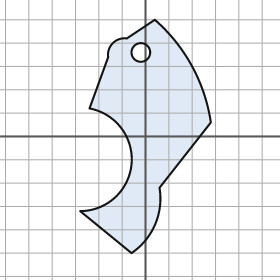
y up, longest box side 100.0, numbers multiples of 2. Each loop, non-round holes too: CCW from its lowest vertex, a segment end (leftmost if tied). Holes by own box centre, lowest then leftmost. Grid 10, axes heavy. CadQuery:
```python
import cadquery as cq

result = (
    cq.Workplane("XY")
    .moveTo(-6.0, -50.0)
    .threePointArc((4.0, -38.0), (6.0, -22.0))
    .lineTo(28.0, 6.0)
    .threePointArc((20.0, 30.0), (4.0, 50.0))
    .lineTo(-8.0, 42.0)
    .threePointArc((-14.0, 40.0), (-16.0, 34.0))
    .lineTo(-24.0, 12.0)
    .threePointArc((-6.0, -12.0), (-28.0, -32.0))
    .close()
    .moveTo(-2.0, 36.0)
    .circle(4.0)
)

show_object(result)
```